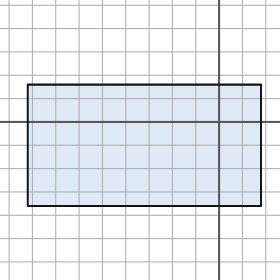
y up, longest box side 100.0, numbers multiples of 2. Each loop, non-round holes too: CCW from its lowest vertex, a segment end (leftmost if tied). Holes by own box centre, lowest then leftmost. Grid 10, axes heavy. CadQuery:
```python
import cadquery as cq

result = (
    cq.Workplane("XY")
    .moveTo(-82.0, -36.0)
    .lineTo(18.0, -36.0)
    .lineTo(18.0, 16.0)
    .lineTo(-82.0, 16.0)
    .close()
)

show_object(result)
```